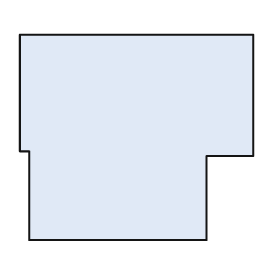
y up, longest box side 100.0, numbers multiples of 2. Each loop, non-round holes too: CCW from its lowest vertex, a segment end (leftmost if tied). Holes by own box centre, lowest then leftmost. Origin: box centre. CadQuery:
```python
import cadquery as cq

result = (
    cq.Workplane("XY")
    .moveTo(-46.0, -44.0)
    .lineTo(30.0, -44.0)
    .lineTo(30.0, -8.0)
    .lineTo(50.0, -8.0)
    .lineTo(50.0, 44.0)
    .lineTo(-50.0, 44.0)
    .lineTo(-50.0, -6.0)
    .lineTo(-46.0, -6.0)
    .close()
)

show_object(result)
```